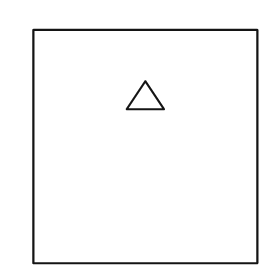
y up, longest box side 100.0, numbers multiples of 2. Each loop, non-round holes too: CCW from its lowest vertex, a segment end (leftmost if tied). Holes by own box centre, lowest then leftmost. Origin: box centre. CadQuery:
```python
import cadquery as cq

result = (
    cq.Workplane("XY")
    .moveTo(-48.0, -50.0)
    .lineTo(48.0, -50.0)
    .lineTo(48.0, 50.0)
    .lineTo(-48.0, 50.0)
    .close()
    .moveTo(-8.0, 16.0)
    .lineTo(8.0, 16.0)
    .lineTo(0.0, 28.0)
    .close()
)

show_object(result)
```